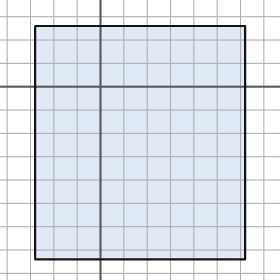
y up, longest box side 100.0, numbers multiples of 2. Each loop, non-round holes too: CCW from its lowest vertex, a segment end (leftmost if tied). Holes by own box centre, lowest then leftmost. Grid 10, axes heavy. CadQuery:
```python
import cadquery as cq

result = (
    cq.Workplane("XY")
    .moveTo(-28.0, -74.0)
    .lineTo(62.0, -74.0)
    .lineTo(62.0, 26.0)
    .lineTo(-28.0, 26.0)
    .close()
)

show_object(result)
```